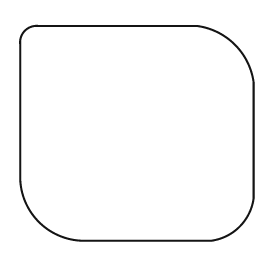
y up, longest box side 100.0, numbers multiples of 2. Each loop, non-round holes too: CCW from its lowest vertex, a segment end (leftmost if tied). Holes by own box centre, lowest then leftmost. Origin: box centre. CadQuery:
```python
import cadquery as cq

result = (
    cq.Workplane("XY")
    .moveTo(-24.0, -46.0)
    .lineTo(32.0, -46.0)
    .threePointArc((44.0, -40.0), (50.0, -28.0))
    .lineTo(50.0, 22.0)
    .threePointArc((42.0, 38.0), (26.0, 46.0))
    .lineTo(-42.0, 46.0)
    .threePointArc((-48.0, 44.0), (-50.0, 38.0))
    .lineTo(-50.0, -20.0)
    .threePointArc((-42.0, -38.0), (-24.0, -46.0))
    .close()
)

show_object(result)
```